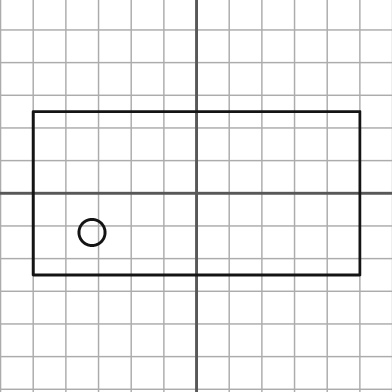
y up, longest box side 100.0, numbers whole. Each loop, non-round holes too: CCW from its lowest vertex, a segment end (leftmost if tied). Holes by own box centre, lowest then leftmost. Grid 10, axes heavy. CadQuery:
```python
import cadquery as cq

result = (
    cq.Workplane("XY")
    .moveTo(-50.0, -25.0)
    .lineTo(50.0, -25.0)
    .lineTo(50.0, 25.0)
    .lineTo(-50.0, 25.0)
    .close()
    .moveTo(-32.0, -12.0)
    .circle(4.0)
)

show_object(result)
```